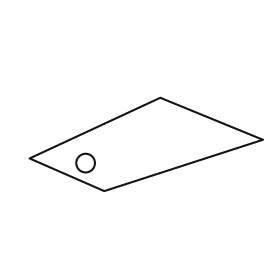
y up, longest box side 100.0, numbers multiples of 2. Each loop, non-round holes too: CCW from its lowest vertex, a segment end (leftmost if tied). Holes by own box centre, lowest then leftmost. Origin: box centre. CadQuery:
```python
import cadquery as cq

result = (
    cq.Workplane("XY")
    .moveTo(-18.0, -20.0)
    .lineTo(50.0, 2.0)
    .lineTo(6.0, 20.0)
    .lineTo(-50.0, -6.0)
    .close()
    .moveTo(-26.0, -8.0)
    .circle(4.0)
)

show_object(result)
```